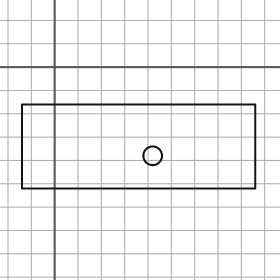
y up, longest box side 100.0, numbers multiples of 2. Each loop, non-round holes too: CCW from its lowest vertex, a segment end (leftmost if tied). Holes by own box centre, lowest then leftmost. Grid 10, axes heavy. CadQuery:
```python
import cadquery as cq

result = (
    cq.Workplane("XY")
    .moveTo(-14.0, -52.0)
    .lineTo(86.0, -52.0)
    .lineTo(86.0, -16.0)
    .lineTo(-14.0, -16.0)
    .close()
    .moveTo(42.0, -38.0)
    .circle(4.0)
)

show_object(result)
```